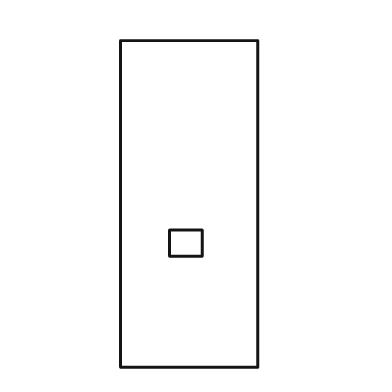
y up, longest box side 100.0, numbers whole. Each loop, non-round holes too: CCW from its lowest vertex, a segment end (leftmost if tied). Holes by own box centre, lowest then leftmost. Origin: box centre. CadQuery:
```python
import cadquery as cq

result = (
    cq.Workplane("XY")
    .moveTo(-21.0, -50.0)
    .lineTo(21.0, -50.0)
    .lineTo(21.0, 50.0)
    .lineTo(-21.0, 50.0)
    .close()
    .moveTo(-6.0, -16.0)
    .lineTo(4.0, -16.0)
    .lineTo(4.0, -8.0)
    .lineTo(-6.0, -8.0)
    .close()
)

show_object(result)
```